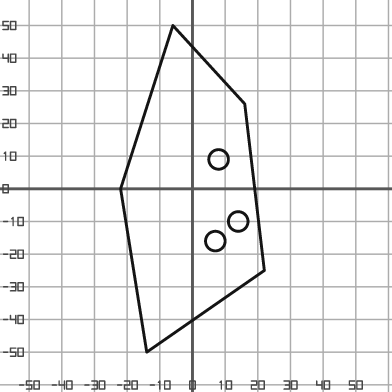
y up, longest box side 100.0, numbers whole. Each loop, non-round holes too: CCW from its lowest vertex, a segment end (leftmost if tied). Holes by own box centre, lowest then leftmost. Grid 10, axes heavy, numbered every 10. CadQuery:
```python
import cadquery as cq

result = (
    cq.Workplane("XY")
    .moveTo(-14.0, -50.0)
    .lineTo(22.0, -25.0)
    .lineTo(16.0, 26.0)
    .lineTo(-6.0, 50.0)
    .lineTo(-22.0, 0.0)
    .close()
    .moveTo(7.0, -16.0)
    .circle(3.0)
    .moveTo(14.0, -10.0)
    .circle(3.0)
    .moveTo(8.0, 9.0)
    .circle(3.0)
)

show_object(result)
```